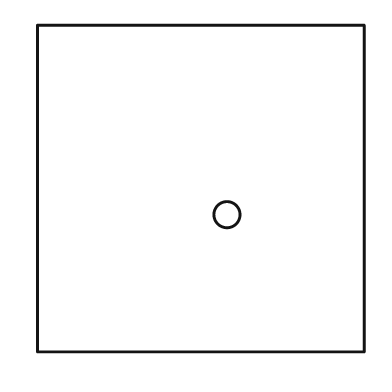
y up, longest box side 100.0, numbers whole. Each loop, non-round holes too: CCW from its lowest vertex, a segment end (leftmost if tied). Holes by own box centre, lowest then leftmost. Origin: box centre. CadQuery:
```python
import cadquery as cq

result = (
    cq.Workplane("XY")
    .moveTo(-50.0, -50.0)
    .lineTo(50.0, -50.0)
    .lineTo(50.0, 50.0)
    .lineTo(-50.0, 50.0)
    .close()
    .moveTo(8.0, -8.0)
    .circle(4.0)
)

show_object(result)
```